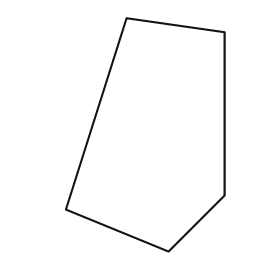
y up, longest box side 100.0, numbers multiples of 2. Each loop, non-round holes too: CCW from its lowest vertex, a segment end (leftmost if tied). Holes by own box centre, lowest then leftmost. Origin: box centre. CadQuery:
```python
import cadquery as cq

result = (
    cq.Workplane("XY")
    .moveTo(10.0, -50.0)
    .lineTo(34.0, -26.0)
    .lineTo(34.0, 44.0)
    .lineTo(-8.0, 50.0)
    .lineTo(-34.0, -32.0)
    .close()
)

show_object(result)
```